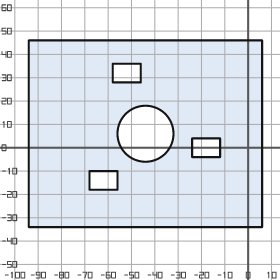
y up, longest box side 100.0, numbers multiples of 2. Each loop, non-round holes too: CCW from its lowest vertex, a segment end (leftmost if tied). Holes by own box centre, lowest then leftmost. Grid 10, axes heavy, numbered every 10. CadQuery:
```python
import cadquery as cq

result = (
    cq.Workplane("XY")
    .moveTo(-94.0, -34.0)
    .lineTo(6.0, -34.0)
    .lineTo(6.0, 46.0)
    .lineTo(-94.0, 46.0)
    .close()
    .moveTo(-68.0, -18.0)
    .lineTo(-56.0, -18.0)
    .lineTo(-56.0, -10.0)
    .lineTo(-68.0, -10.0)
    .close()
    .moveTo(-24.0, -4.0)
    .lineTo(-12.0, -4.0)
    .lineTo(-12.0, 4.0)
    .lineTo(-24.0, 4.0)
    .close()
    .moveTo(-44.0, 6.0)
    .circle(12.0)
    .moveTo(-58.0, 28.0)
    .lineTo(-46.0, 28.0)
    .lineTo(-46.0, 36.0)
    .lineTo(-58.0, 36.0)
    .close()
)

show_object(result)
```